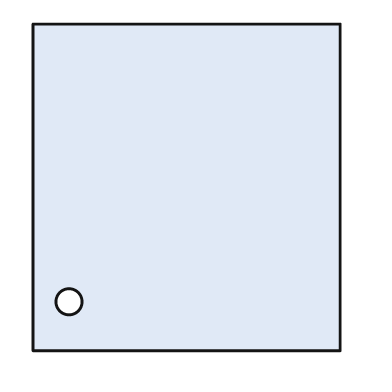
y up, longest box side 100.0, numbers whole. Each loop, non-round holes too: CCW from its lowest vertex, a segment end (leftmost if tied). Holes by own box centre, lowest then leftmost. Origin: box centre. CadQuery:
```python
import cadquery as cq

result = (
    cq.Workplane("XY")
    .moveTo(-47.0, -50.0)
    .lineTo(47.0, -50.0)
    .lineTo(47.0, 50.0)
    .lineTo(-47.0, 50.0)
    .close()
    .moveTo(-36.0, -35.0)
    .circle(4.0)
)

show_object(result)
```